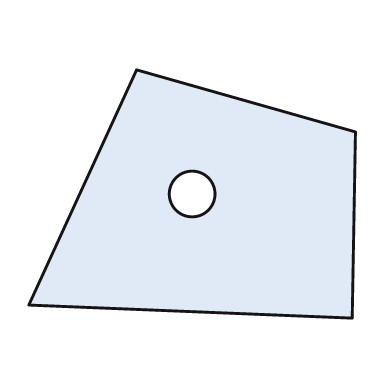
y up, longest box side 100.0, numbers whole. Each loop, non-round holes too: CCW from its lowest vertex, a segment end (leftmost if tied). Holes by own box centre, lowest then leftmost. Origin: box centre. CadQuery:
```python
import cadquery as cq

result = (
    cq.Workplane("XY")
    .moveTo(49.0, -38.0)
    .lineTo(50.0, 19.0)
    .lineTo(-17.0, 38.0)
    .lineTo(-50.0, -34.0)
    .close()
    .moveTo(0.0, 0.0)
    .circle(7.0)
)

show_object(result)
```